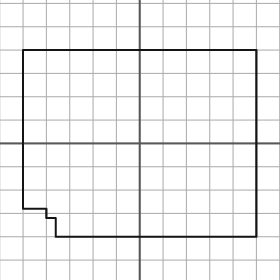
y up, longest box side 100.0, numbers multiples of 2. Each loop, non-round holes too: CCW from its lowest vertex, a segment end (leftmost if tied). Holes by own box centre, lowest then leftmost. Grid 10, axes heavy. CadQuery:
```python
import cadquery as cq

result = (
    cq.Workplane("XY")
    .moveTo(-36.0, -40.0)
    .lineTo(50.0, -40.0)
    .lineTo(50.0, 40.0)
    .lineTo(-50.0, 40.0)
    .lineTo(-50.0, -28.0)
    .lineTo(-40.0, -28.0)
    .lineTo(-40.0, -32.0)
    .lineTo(-36.0, -32.0)
    .close()
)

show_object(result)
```